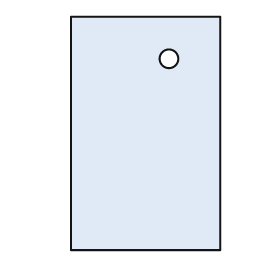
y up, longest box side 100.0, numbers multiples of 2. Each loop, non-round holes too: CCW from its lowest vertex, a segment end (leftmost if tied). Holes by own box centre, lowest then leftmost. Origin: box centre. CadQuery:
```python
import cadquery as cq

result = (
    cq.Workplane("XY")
    .moveTo(-32.0, -50.0)
    .lineTo(32.0, -50.0)
    .lineTo(32.0, 50.0)
    .lineTo(-32.0, 50.0)
    .close()
    .moveTo(10.0, 32.0)
    .circle(4.0)
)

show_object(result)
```